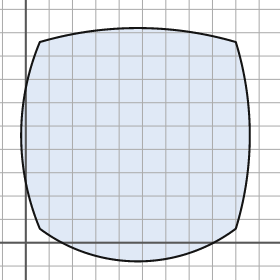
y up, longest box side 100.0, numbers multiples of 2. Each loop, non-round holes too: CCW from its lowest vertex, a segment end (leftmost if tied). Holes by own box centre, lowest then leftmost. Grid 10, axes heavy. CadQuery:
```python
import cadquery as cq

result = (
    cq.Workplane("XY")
    .moveTo(6.0, 6.0)
    .threePointArc((48.0, -8.0), (90.0, 6.0))
    .threePointArc((96.0, 46.0), (90.0, 86.0))
    .threePointArc((48.0, 92.0), (6.0, 86.0))
    .threePointArc((-2.0, 46.0), (6.0, 6.0))
    .close()
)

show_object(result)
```